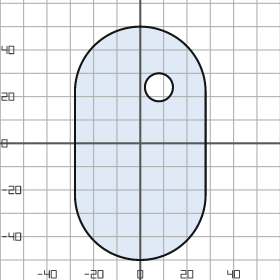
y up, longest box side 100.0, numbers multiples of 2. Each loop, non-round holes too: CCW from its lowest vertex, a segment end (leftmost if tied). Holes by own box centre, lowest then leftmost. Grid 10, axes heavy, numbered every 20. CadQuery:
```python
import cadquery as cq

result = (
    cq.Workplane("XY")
    .moveTo(-28.0, -22.0)
    .threePointArc((0.0, -50.0), (28.0, -22.0))
    .lineTo(28.0, 22.0)
    .threePointArc((0.0, 50.0), (-28.0, 22.0))
    .close()
    .moveTo(8.0, 24.0)
    .circle(6.0)
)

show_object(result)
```